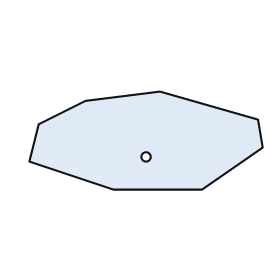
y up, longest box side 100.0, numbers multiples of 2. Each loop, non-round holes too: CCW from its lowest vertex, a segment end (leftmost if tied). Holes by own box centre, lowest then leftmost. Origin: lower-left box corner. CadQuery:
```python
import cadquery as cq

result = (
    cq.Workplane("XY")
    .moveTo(36.0, 0.0)
    .lineTo(74.0, 0.0)
    .lineTo(100.0, 18.0)
    .lineTo(98.0, 30.0)
    .lineTo(56.0, 42.0)
    .lineTo(24.0, 38.0)
    .lineTo(4.0, 28.0)
    .lineTo(0.0, 12.0)
    .close()
    .moveTo(50.0, 14.0)
    .circle(2.0)
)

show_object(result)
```